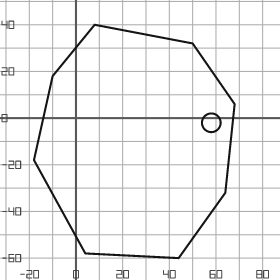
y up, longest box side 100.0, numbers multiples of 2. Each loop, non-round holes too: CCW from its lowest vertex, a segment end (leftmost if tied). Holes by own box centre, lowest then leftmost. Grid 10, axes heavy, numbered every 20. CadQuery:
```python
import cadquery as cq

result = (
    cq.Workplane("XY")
    .moveTo(44.0, -60.0)
    .lineTo(64.0, -32.0)
    .lineTo(68.0, 6.0)
    .lineTo(50.0, 32.0)
    .lineTo(8.0, 40.0)
    .lineTo(-10.0, 18.0)
    .lineTo(-18.0, -18.0)
    .lineTo(4.0, -58.0)
    .close()
    .moveTo(58.0, -2.0)
    .circle(4.0)
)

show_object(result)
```